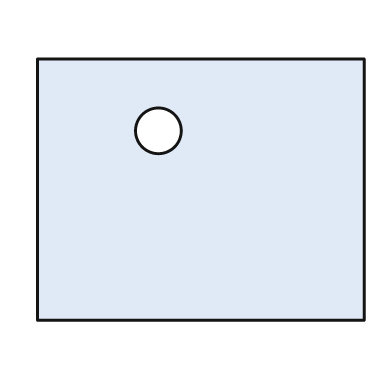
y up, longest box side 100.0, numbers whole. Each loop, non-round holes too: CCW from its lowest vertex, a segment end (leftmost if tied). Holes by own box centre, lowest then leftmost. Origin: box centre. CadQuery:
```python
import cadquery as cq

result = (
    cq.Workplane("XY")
    .moveTo(-50.0, -40.0)
    .lineTo(50.0, -40.0)
    .lineTo(50.0, 40.0)
    .lineTo(-50.0, 40.0)
    .close()
    .moveTo(-13.0, 18.0)
    .circle(7.0)
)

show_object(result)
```